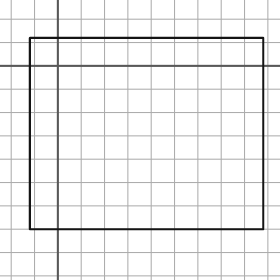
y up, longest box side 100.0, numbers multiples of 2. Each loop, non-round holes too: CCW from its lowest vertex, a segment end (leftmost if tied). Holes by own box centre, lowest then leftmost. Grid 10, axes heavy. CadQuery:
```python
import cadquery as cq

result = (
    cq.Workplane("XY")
    .moveTo(-12.0, -70.0)
    .lineTo(88.0, -70.0)
    .lineTo(88.0, 12.0)
    .lineTo(-12.0, 12.0)
    .close()
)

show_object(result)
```